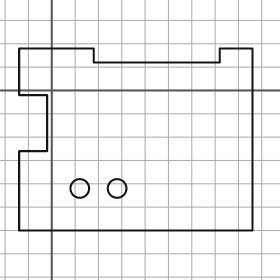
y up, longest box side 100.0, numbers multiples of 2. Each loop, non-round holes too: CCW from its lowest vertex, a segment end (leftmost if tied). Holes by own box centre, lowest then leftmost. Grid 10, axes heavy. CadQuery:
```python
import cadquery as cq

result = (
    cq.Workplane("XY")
    .moveTo(-14.0, -60.0)
    .lineTo(86.0, -60.0)
    .lineTo(86.0, 18.0)
    .lineTo(72.0, 18.0)
    .lineTo(72.0, 12.0)
    .lineTo(18.0, 12.0)
    .lineTo(18.0, 18.0)
    .lineTo(-14.0, 18.0)
    .lineTo(-14.0, -2.0)
    .lineTo(-2.0, -2.0)
    .lineTo(-2.0, -26.0)
    .lineTo(-14.0, -26.0)
    .close()
    .moveTo(12.0, -42.0)
    .circle(4.0)
    .moveTo(28.0, -42.0)
    .circle(4.0)
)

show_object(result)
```